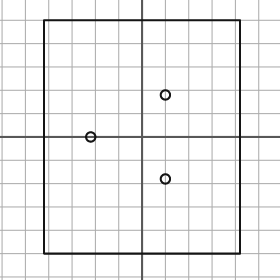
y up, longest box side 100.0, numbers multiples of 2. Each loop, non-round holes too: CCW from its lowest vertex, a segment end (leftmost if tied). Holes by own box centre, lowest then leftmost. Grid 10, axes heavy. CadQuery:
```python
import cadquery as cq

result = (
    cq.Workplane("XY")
    .moveTo(-42.0, -50.0)
    .lineTo(42.0, -50.0)
    .lineTo(42.0, 50.0)
    .lineTo(-42.0, 50.0)
    .close()
    .moveTo(10.0, -18.0)
    .circle(2.0)
    .moveTo(-22.0, 0.0)
    .circle(2.0)
    .moveTo(10.0, 18.0)
    .circle(2.0)
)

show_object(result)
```